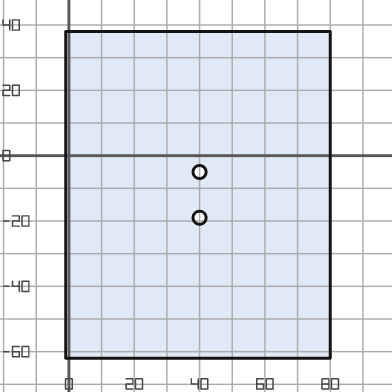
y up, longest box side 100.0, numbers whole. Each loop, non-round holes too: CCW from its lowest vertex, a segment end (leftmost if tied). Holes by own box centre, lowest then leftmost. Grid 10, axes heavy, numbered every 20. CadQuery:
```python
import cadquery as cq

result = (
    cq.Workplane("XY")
    .moveTo(-1.0, -62.0)
    .lineTo(80.0, -62.0)
    .lineTo(80.0, 38.0)
    .lineTo(-1.0, 38.0)
    .close()
    .moveTo(40.0, -19.0)
    .circle(2.0)
    .moveTo(40.0, -5.0)
    .circle(2.0)
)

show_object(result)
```